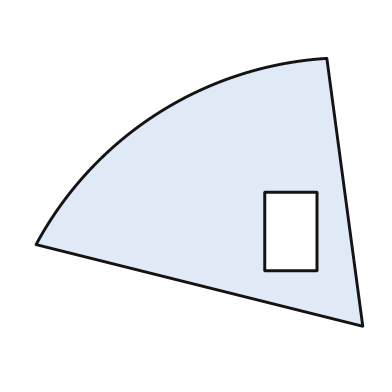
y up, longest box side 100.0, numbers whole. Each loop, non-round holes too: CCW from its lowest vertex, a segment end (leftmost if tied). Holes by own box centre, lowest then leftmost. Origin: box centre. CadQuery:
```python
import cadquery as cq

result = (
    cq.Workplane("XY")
    .moveTo(50.0, -41.0)
    .lineTo(39.0, 41.0)
    .threePointArc((-13.0, 24.0), (-50.0, -16.0))
    .close()
    .moveTo(20.0, -24.0)
    .lineTo(36.0, -24.0)
    .lineTo(36.0, 0.0)
    .lineTo(20.0, 0.0)
    .close()
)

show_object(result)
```